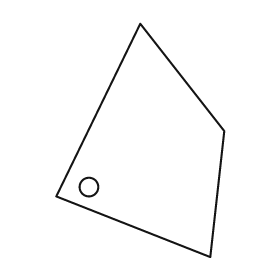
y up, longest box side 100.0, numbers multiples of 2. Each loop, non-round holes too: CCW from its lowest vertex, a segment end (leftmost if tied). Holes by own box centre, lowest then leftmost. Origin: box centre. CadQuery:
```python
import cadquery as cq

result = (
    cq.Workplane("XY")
    .moveTo(30.0, -50.0)
    .lineTo(36.0, 4.0)
    .lineTo(0.0, 50.0)
    .lineTo(-36.0, -24.0)
    .close()
    .moveTo(-22.0, -20.0)
    .circle(4.0)
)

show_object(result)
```